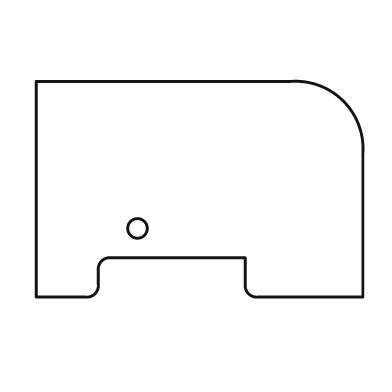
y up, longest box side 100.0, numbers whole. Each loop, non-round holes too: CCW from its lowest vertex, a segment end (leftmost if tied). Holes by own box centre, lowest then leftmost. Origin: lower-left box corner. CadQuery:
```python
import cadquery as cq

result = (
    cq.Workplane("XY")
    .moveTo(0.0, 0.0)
    .lineTo(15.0, 0.0)
    .threePointArc((18.0, 1.0), (19.0, 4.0))
    .lineTo(19.0, 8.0)
    .threePointArc((20.0, 11.0), (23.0, 12.0))
    .lineTo(64.0, 12.0)
    .lineTo(64.0, 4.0)
    .threePointArc((65.0, 1.0), (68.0, 0.0))
    .lineTo(100.0, 0.0)
    .lineTo(100.0, 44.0)
    .threePointArc((94.0, 60.0), (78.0, 66.0))
    .lineTo(0.0, 66.0)
    .close()
    .moveTo(31.0, 21.0)
    .circle(3.0)
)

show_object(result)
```